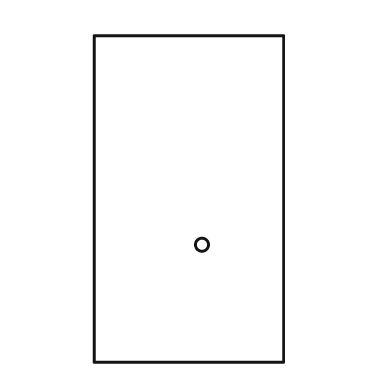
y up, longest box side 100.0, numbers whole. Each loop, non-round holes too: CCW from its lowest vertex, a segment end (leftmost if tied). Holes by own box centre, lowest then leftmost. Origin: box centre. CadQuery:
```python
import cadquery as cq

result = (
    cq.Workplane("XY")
    .moveTo(-29.0, -50.0)
    .lineTo(29.0, -50.0)
    .lineTo(29.0, 50.0)
    .lineTo(-29.0, 50.0)
    .close()
    .moveTo(4.0, -14.0)
    .circle(2.0)
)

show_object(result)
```